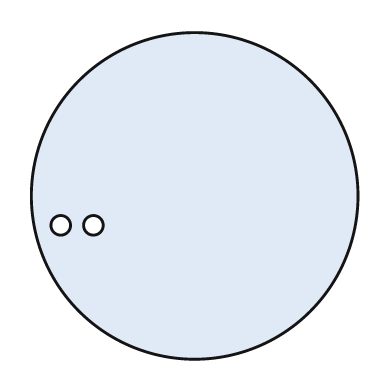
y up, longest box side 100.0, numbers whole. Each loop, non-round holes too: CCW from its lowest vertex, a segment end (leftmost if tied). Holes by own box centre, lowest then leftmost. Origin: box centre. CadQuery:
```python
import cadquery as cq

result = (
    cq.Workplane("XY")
    .moveTo(0.0, 0.0)
    .circle(50.0)
    .moveTo(-41.0, -9.0)
    .circle(3.0)
    .moveTo(-31.0, -9.0)
    .circle(3.0)
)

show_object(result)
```